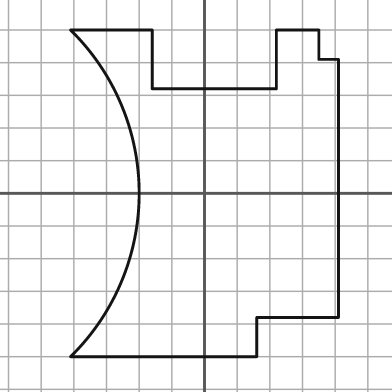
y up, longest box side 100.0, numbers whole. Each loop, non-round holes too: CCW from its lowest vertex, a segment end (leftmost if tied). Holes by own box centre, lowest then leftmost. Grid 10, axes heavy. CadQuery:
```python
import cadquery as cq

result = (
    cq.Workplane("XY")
    .moveTo(-41.0, -50.0)
    .lineTo(16.0, -50.0)
    .lineTo(16.0, -38.0)
    .lineTo(41.0, -38.0)
    .lineTo(41.0, 41.0)
    .lineTo(35.0, 41.0)
    .lineTo(35.0, 50.0)
    .lineTo(22.0, 50.0)
    .lineTo(22.0, 32.0)
    .lineTo(-16.0, 32.0)
    .lineTo(-16.0, 50.0)
    .lineTo(-41.0, 50.0)
    .threePointArc((-20.0, 0.0), (-41.0, -50.0))
    .close()
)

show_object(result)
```